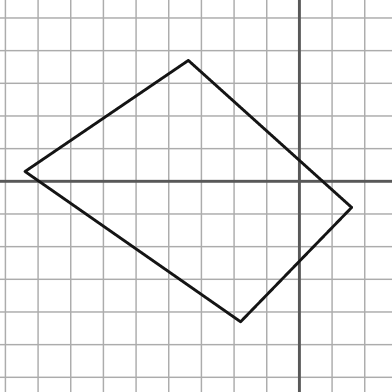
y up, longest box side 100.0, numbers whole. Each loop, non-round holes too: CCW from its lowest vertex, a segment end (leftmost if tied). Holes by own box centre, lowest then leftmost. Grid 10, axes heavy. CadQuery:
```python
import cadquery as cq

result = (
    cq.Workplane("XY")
    .moveTo(-18.0, -43.0)
    .lineTo(16.0, -8.0)
    .lineTo(-34.0, 37.0)
    .lineTo(-84.0, 3.0)
    .close()
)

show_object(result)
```